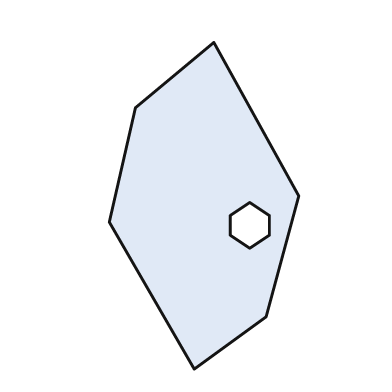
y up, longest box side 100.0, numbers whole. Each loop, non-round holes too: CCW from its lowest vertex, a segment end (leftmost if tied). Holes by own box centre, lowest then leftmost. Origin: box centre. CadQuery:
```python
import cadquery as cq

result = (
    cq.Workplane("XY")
    .moveTo(-3.0, -50.0)
    .lineTo(19.0, -34.0)
    .lineTo(29.0, 3.0)
    .lineTo(3.0, 50.0)
    .lineTo(-21.0, 30.0)
    .lineTo(-29.0, -5.0)
    .close()
    .moveTo(14.0, -13.0)
    .lineTo(20.0, -9.0)
    .lineTo(20.0, -3.0)
    .lineTo(14.0, 1.0)
    .lineTo(8.0, -3.0)
    .lineTo(8.0, -9.0)
    .close()
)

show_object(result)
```